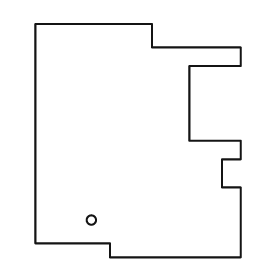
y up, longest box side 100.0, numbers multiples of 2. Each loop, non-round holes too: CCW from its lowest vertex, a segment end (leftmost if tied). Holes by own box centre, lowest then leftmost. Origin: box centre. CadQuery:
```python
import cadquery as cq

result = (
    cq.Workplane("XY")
    .moveTo(-12.0, -50.0)
    .lineTo(44.0, -50.0)
    .lineTo(44.0, -20.0)
    .lineTo(36.0, -20.0)
    .lineTo(36.0, -8.0)
    .lineTo(44.0, -8.0)
    .lineTo(44.0, 0.0)
    .lineTo(22.0, 0.0)
    .lineTo(22.0, 32.0)
    .lineTo(44.0, 32.0)
    .lineTo(44.0, 40.0)
    .lineTo(6.0, 40.0)
    .lineTo(6.0, 50.0)
    .lineTo(-44.0, 50.0)
    .lineTo(-44.0, -44.0)
    .lineTo(-12.0, -44.0)
    .close()
    .moveTo(-20.0, -34.0)
    .circle(2.0)
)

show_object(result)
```